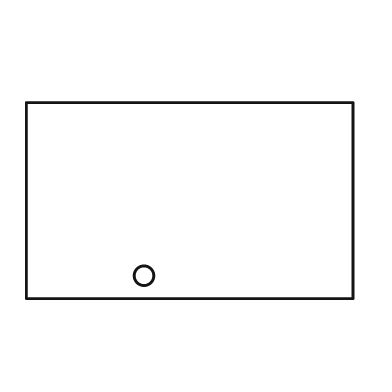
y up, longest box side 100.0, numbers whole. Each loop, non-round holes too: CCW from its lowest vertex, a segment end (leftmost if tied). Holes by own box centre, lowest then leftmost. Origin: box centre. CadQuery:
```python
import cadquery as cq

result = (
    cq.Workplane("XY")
    .moveTo(-50.0, -30.0)
    .lineTo(50.0, -30.0)
    .lineTo(50.0, 30.0)
    .lineTo(-50.0, 30.0)
    .close()
    .moveTo(-14.0, -23.0)
    .circle(3.0)
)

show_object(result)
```